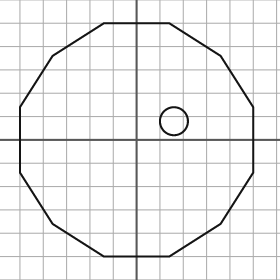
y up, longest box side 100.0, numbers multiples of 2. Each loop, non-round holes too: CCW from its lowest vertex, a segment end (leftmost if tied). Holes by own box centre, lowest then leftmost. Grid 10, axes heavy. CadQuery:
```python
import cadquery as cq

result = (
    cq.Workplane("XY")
    .moveTo(-14.0, -50.0)
    .lineTo(14.0, -50.0)
    .lineTo(36.0, -36.0)
    .lineTo(50.0, -14.0)
    .lineTo(50.0, 14.0)
    .lineTo(36.0, 36.0)
    .lineTo(14.0, 50.0)
    .lineTo(-14.0, 50.0)
    .lineTo(-36.0, 36.0)
    .lineTo(-50.0, 14.0)
    .lineTo(-50.0, -14.0)
    .lineTo(-36.0, -36.0)
    .close()
    .moveTo(16.0, 8.0)
    .circle(6.0)
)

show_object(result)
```